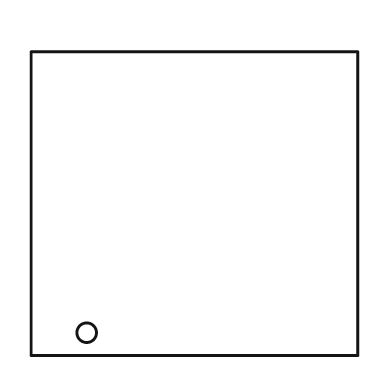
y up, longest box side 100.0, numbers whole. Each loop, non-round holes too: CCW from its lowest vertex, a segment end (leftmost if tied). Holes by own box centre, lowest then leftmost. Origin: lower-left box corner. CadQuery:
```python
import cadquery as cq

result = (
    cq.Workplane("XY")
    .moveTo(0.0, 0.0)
    .lineTo(100.0, 0.0)
    .lineTo(100.0, 93.0)
    .lineTo(0.0, 93.0)
    .close()
    .moveTo(17.0, 7.0)
    .circle(3.0)
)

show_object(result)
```